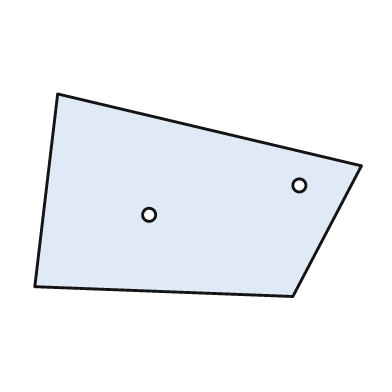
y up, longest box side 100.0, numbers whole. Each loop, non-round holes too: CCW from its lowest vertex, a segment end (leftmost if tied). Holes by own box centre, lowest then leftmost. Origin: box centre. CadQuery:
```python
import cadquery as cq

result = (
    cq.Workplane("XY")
    .moveTo(29.0, -31.0)
    .lineTo(50.0, 9.0)
    .lineTo(-43.0, 31.0)
    .lineTo(-50.0, -28.0)
    .close()
    .moveTo(-15.0, -6.0)
    .circle(2.0)
    .moveTo(31.0, 3.0)
    .circle(2.0)
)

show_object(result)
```